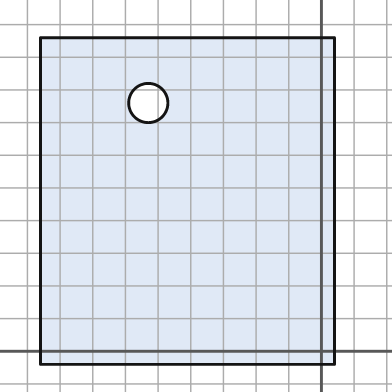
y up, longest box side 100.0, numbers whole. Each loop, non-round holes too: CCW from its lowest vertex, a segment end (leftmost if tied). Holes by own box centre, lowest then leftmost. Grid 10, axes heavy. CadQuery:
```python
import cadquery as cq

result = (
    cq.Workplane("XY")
    .moveTo(-86.0, -4.0)
    .lineTo(4.0, -4.0)
    .lineTo(4.0, 96.0)
    .lineTo(-86.0, 96.0)
    .close()
    .moveTo(-53.0, 76.0)
    .circle(6.0)
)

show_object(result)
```